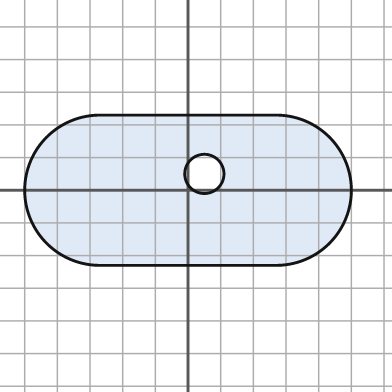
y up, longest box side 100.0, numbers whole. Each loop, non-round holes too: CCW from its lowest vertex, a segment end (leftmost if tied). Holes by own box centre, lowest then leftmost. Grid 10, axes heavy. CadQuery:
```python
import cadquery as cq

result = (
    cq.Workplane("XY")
    .moveTo(-27.0, -23.0)
    .lineTo(27.0, -23.0)
    .threePointArc((50.0, 0.0), (27.0, 23.0))
    .lineTo(-27.0, 23.0)
    .threePointArc((-50.0, 0.0), (-27.0, -23.0))
    .close()
    .moveTo(5.0, 5.0)
    .circle(6.0)
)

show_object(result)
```